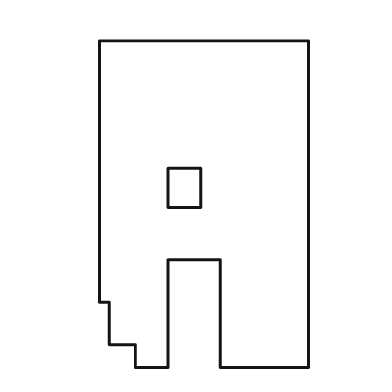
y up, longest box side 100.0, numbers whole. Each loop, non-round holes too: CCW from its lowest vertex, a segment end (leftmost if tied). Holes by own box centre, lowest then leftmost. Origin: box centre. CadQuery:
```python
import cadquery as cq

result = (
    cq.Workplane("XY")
    .moveTo(-21.0, -50.0)
    .lineTo(-11.0, -50.0)
    .lineTo(-11.0, -17.0)
    .lineTo(5.0, -17.0)
    .lineTo(5.0, -50.0)
    .lineTo(32.0, -50.0)
    .lineTo(32.0, 50.0)
    .lineTo(-32.0, 50.0)
    .lineTo(-32.0, -30.0)
    .lineTo(-29.0, -30.0)
    .lineTo(-29.0, -43.0)
    .lineTo(-21.0, -43.0)
    .close()
    .moveTo(-11.0, -1.0)
    .lineTo(-1.0, -1.0)
    .lineTo(-1.0, 11.0)
    .lineTo(-11.0, 11.0)
    .close()
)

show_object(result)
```